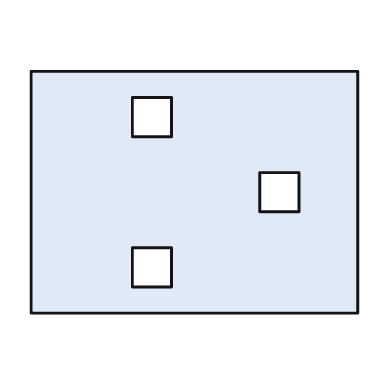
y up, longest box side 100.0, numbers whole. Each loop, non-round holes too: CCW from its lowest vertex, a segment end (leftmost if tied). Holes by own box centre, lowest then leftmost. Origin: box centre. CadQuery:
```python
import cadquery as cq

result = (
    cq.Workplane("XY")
    .moveTo(-50.0, -37.0)
    .lineTo(50.0, -37.0)
    .lineTo(50.0, 37.0)
    .lineTo(-50.0, 37.0)
    .close()
    .moveTo(-19.0, -29.0)
    .lineTo(-7.0, -29.0)
    .lineTo(-7.0, -17.0)
    .lineTo(-19.0, -17.0)
    .close()
    .moveTo(20.0, -6.0)
    .lineTo(32.0, -6.0)
    .lineTo(32.0, 6.0)
    .lineTo(20.0, 6.0)
    .close()
    .moveTo(-19.0, 17.0)
    .lineTo(-7.0, 17.0)
    .lineTo(-7.0, 29.0)
    .lineTo(-19.0, 29.0)
    .close()
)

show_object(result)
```